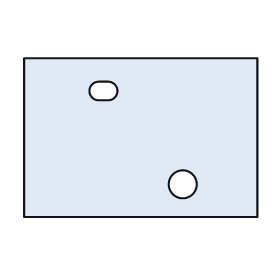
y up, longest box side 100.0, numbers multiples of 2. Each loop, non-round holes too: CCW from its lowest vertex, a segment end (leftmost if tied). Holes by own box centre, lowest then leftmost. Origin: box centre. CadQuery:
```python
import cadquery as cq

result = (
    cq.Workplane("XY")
    .moveTo(-50.0, -34.0)
    .lineTo(50.0, -34.0)
    .lineTo(50.0, 34.0)
    .lineTo(-50.0, 34.0)
    .close()
    .moveTo(18.0, -20.0)
    .circle(6.0)
    .moveTo(-18.0, 16.0)
    .lineTo(-14.0, 16.0)
    .threePointArc((-10.0, 20.0), (-14.0, 24.0))
    .lineTo(-18.0, 24.0)
    .threePointArc((-22.0, 20.0), (-18.0, 16.0))
    .close()
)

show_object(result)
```